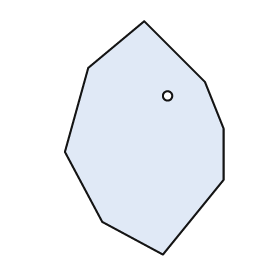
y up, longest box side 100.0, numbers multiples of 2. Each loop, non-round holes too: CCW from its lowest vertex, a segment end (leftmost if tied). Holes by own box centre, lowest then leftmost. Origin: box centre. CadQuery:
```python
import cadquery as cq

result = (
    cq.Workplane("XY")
    .moveTo(8.0, -50.0)
    .lineTo(34.0, -18.0)
    .lineTo(34.0, 4.0)
    .lineTo(26.0, 24.0)
    .lineTo(0.0, 50.0)
    .lineTo(-24.0, 30.0)
    .lineTo(-34.0, -6.0)
    .lineTo(-18.0, -36.0)
    .close()
    .moveTo(10.0, 18.0)
    .circle(2.0)
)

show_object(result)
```